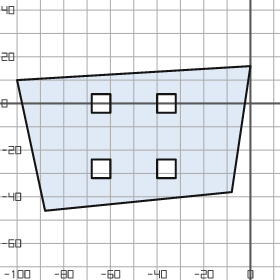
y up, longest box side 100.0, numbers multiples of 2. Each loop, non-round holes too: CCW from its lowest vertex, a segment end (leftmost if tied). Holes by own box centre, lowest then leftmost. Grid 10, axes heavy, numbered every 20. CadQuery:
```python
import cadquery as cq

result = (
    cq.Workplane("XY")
    .moveTo(-88.0, -46.0)
    .lineTo(-8.0, -38.0)
    .lineTo(0.0, 16.0)
    .lineTo(-100.0, 10.0)
    .close()
    .moveTo(-68.0, -32.0)
    .lineTo(-60.0, -32.0)
    .lineTo(-60.0, -24.0)
    .lineTo(-68.0, -24.0)
    .close()
    .moveTo(-40.0, -32.0)
    .lineTo(-32.0, -32.0)
    .lineTo(-32.0, -24.0)
    .lineTo(-40.0, -24.0)
    .close()
    .moveTo(-68.0, -4.0)
    .lineTo(-60.0, -4.0)
    .lineTo(-60.0, 4.0)
    .lineTo(-68.0, 4.0)
    .close()
    .moveTo(-40.0, -4.0)
    .lineTo(-32.0, -4.0)
    .lineTo(-32.0, 4.0)
    .lineTo(-40.0, 4.0)
    .close()
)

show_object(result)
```